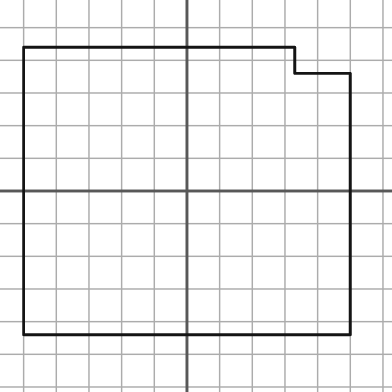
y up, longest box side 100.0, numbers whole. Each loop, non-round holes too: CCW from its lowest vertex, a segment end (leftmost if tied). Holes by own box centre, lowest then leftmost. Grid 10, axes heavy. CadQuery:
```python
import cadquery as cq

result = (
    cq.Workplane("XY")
    .moveTo(-50.0, -44.0)
    .lineTo(50.0, -44.0)
    .lineTo(50.0, 36.0)
    .lineTo(33.0, 36.0)
    .lineTo(33.0, 44.0)
    .lineTo(-50.0, 44.0)
    .close()
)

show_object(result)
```